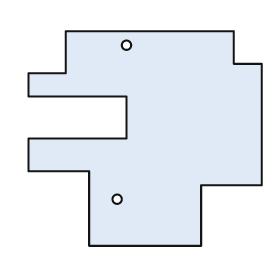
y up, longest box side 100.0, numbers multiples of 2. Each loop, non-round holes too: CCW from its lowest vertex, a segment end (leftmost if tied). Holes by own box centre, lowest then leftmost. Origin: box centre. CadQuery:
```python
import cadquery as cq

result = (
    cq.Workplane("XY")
    .moveTo(-24.0, -46.0)
    .lineTo(24.0, -46.0)
    .lineTo(24.0, -20.0)
    .lineTo(50.0, -20.0)
    .lineTo(50.0, 32.0)
    .lineTo(38.0, 32.0)
    .lineTo(38.0, 46.0)
    .lineTo(-34.0, 46.0)
    .lineTo(-34.0, 28.0)
    .lineTo(-50.0, 28.0)
    .lineTo(-50.0, 18.0)
    .lineTo(-8.0, 18.0)
    .lineTo(-8.0, 0.0)
    .lineTo(-50.0, 0.0)
    .lineTo(-50.0, -14.0)
    .lineTo(-24.0, -14.0)
    .close()
    .moveTo(-12.0, -26.0)
    .circle(2.0)
    .moveTo(-8.0, 40.0)
    .circle(2.0)
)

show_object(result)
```